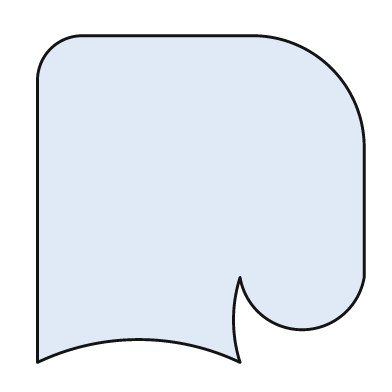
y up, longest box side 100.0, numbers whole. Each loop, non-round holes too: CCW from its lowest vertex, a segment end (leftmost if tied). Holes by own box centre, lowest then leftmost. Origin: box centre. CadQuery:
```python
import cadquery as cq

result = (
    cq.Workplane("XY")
    .moveTo(-50.0, -50.0)
    .threePointArc((-19.0, -43.0), (12.0, -50.0))
    .threePointArc((10.0, -37.0), (12.0, -24.0))
    .threePointArc((31.0, -40.0), (50.0, -24.0))
    .lineTo(50.0, 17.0)
    .threePointArc((40.0, 40.0), (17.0, 50.0))
    .lineTo(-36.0, 50.0)
    .threePointArc((-46.0, 46.0), (-50.0, 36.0))
    .close()
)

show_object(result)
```